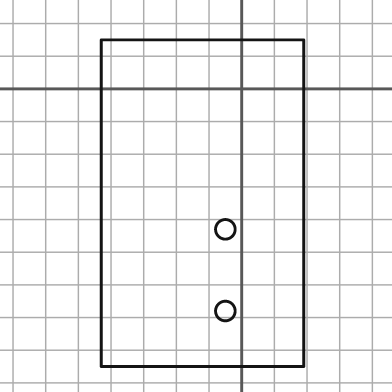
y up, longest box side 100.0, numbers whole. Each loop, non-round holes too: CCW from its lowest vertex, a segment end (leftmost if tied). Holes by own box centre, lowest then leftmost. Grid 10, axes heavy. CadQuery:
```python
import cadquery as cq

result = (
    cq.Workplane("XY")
    .moveTo(-43.0, -85.0)
    .lineTo(19.0, -85.0)
    .lineTo(19.0, 15.0)
    .lineTo(-43.0, 15.0)
    .close()
    .moveTo(-5.0, -68.0)
    .circle(3.0)
    .moveTo(-5.0, -43.0)
    .circle(3.0)
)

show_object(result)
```